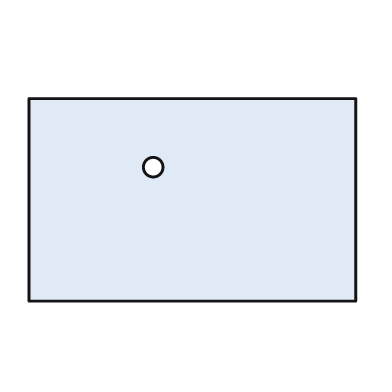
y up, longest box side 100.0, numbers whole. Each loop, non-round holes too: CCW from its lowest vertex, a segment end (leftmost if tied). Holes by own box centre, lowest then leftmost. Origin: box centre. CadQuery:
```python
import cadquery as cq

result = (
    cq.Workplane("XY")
    .moveTo(-50.0, -31.0)
    .lineTo(50.0, -31.0)
    .lineTo(50.0, 31.0)
    .lineTo(-50.0, 31.0)
    .close()
    .moveTo(-12.0, 10.0)
    .circle(3.0)
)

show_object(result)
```